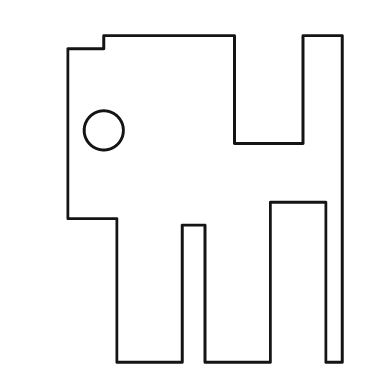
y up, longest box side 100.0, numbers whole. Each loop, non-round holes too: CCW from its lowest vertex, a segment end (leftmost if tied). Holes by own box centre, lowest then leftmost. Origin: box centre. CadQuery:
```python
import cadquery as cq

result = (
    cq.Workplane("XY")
    .moveTo(-27.0, -50.0)
    .lineTo(-7.0, -50.0)
    .lineTo(-7.0, -8.0)
    .lineTo(0.0, -8.0)
    .lineTo(0.0, -50.0)
    .lineTo(20.0, -50.0)
    .lineTo(20.0, -1.0)
    .lineTo(37.0, -1.0)
    .lineTo(37.0, -50.0)
    .lineTo(42.0, -50.0)
    .lineTo(42.0, 50.0)
    .lineTo(30.0, 50.0)
    .lineTo(30.0, 17.0)
    .lineTo(9.0, 17.0)
    .lineTo(9.0, 50.0)
    .lineTo(-31.0, 50.0)
    .lineTo(-31.0, 46.0)
    .lineTo(-42.0, 46.0)
    .lineTo(-42.0, -6.0)
    .lineTo(-27.0, -6.0)
    .close()
    .moveTo(-31.0, 21.0)
    .circle(6.0)
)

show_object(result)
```